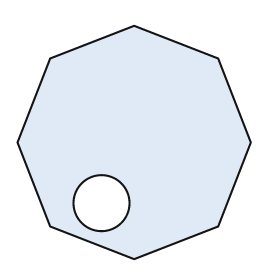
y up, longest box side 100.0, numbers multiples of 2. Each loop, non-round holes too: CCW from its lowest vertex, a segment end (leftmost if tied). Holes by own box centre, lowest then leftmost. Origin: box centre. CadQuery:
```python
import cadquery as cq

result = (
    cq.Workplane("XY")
    .moveTo(0.0, -50.0)
    .lineTo(36.0, -36.0)
    .lineTo(50.0, 0.0)
    .lineTo(36.0, 36.0)
    .lineTo(0.0, 50.0)
    .lineTo(-36.0, 36.0)
    .lineTo(-50.0, 0.0)
    .lineTo(-36.0, -36.0)
    .close()
    .moveTo(-14.0, -26.0)
    .circle(12.0)
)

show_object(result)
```